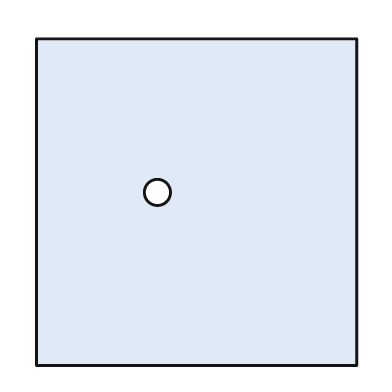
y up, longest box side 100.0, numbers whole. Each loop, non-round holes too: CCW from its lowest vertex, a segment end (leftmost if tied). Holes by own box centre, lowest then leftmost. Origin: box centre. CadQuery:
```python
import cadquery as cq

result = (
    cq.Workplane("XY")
    .moveTo(-49.0, -50.0)
    .lineTo(49.0, -50.0)
    .lineTo(49.0, 50.0)
    .lineTo(-49.0, 50.0)
    .close()
    .moveTo(-12.0, 3.0)
    .circle(4.0)
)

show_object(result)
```